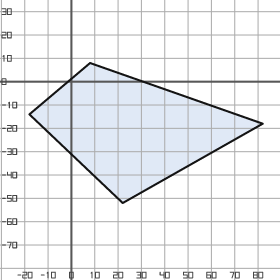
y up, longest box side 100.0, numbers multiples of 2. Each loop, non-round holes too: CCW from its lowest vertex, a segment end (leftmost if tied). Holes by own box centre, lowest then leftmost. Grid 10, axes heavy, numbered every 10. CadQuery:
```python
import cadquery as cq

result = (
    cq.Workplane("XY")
    .moveTo(22.0, -52.0)
    .lineTo(82.0, -18.0)
    .lineTo(8.0, 8.0)
    .lineTo(-18.0, -14.0)
    .close()
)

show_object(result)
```